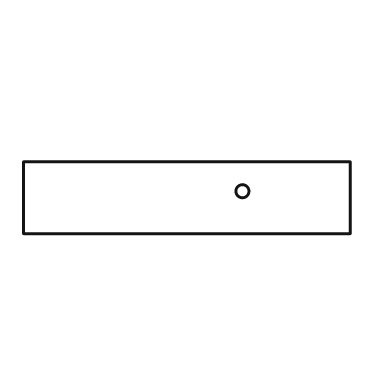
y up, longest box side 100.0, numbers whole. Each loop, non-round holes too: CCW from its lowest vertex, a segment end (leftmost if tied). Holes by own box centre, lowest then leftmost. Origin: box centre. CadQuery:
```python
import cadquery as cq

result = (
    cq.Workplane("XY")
    .moveTo(-50.0, -11.0)
    .lineTo(50.0, -11.0)
    .lineTo(50.0, 11.0)
    .lineTo(-50.0, 11.0)
    .close()
    .moveTo(17.0, 2.0)
    .circle(2.0)
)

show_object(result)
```